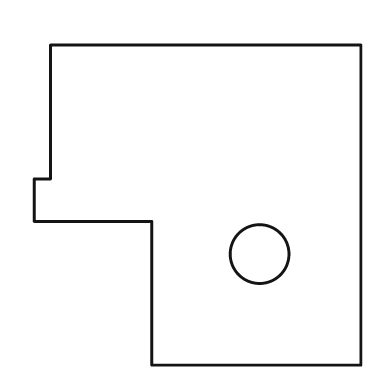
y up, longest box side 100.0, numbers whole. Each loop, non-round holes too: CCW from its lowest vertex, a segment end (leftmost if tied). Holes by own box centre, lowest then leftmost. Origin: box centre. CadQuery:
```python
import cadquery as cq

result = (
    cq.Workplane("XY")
    .moveTo(-14.0, -49.0)
    .lineTo(50.0, -49.0)
    .lineTo(50.0, 49.0)
    .lineTo(-45.0, 49.0)
    .lineTo(-45.0, 8.0)
    .lineTo(-50.0, 8.0)
    .lineTo(-50.0, -5.0)
    .lineTo(-14.0, -5.0)
    .close()
    .moveTo(19.0, -15.0)
    .circle(9.0)
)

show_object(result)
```